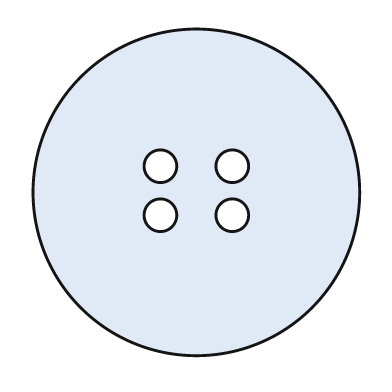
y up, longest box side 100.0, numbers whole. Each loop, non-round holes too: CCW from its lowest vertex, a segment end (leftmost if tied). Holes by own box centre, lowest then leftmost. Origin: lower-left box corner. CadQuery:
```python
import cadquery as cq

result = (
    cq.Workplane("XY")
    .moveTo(50.0, 50.0)
    .circle(50.0)
    .moveTo(39.0, 43.0)
    .circle(5.0)
    .moveTo(61.0, 43.0)
    .circle(5.0)
    .moveTo(39.0, 58.0)
    .circle(5.0)
    .moveTo(61.0, 58.0)
    .circle(5.0)
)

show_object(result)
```